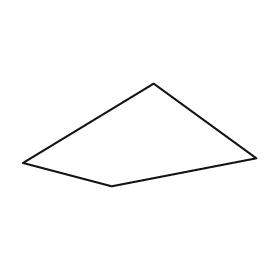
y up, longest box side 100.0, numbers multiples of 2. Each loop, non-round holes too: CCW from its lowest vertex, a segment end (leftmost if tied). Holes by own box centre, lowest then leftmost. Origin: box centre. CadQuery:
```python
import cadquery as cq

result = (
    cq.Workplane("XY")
    .moveTo(-12.0, -22.0)
    .lineTo(50.0, -10.0)
    .lineTo(6.0, 22.0)
    .lineTo(-50.0, -12.0)
    .close()
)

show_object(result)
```